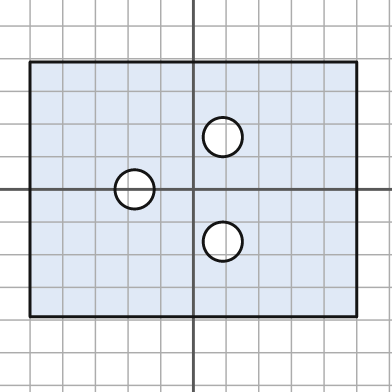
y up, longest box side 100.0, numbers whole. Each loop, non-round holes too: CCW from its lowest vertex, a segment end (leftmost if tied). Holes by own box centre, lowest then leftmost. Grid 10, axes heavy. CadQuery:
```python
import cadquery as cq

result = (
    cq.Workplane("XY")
    .moveTo(-50.0, -39.0)
    .lineTo(50.0, -39.0)
    .lineTo(50.0, 39.0)
    .lineTo(-50.0, 39.0)
    .close()
    .moveTo(9.0, -16.0)
    .circle(6.0)
    .moveTo(-18.0, 0.0)
    .circle(6.0)
    .moveTo(9.0, 16.0)
    .circle(6.0)
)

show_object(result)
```